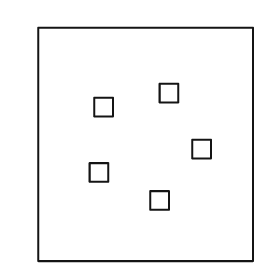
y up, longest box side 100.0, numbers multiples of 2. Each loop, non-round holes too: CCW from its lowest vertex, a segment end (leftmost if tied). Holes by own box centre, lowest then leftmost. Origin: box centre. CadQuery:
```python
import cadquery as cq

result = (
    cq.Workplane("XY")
    .moveTo(-46.0, -50.0)
    .lineTo(46.0, -50.0)
    .lineTo(46.0, 50.0)
    .lineTo(-46.0, 50.0)
    .close()
    .moveTo(2.0, -28.0)
    .lineTo(10.0, -28.0)
    .lineTo(10.0, -20.0)
    .lineTo(2.0, -20.0)
    .close()
    .moveTo(-24.0, -16.0)
    .lineTo(-16.0, -16.0)
    .lineTo(-16.0, -8.0)
    .lineTo(-24.0, -8.0)
    .close()
    .moveTo(20.0, -6.0)
    .lineTo(28.0, -6.0)
    .lineTo(28.0, 2.0)
    .lineTo(20.0, 2.0)
    .close()
    .moveTo(-22.0, 12.0)
    .lineTo(-14.0, 12.0)
    .lineTo(-14.0, 20.0)
    .lineTo(-22.0, 20.0)
    .close()
    .moveTo(6.0, 18.0)
    .lineTo(14.0, 18.0)
    .lineTo(14.0, 26.0)
    .lineTo(6.0, 26.0)
    .close()
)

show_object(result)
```